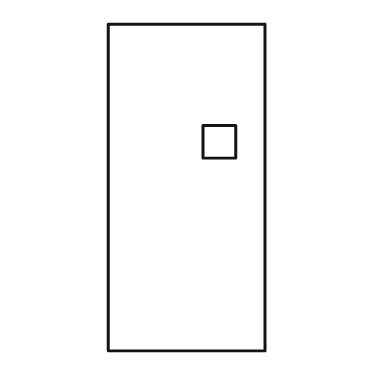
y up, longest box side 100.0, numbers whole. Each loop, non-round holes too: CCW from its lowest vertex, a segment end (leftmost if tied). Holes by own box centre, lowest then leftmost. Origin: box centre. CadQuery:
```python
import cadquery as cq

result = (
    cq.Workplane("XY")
    .moveTo(-24.0, -50.0)
    .lineTo(24.0, -50.0)
    .lineTo(24.0, 50.0)
    .lineTo(-24.0, 50.0)
    .close()
    .moveTo(5.0, 9.0)
    .lineTo(15.0, 9.0)
    .lineTo(15.0, 19.0)
    .lineTo(5.0, 19.0)
    .close()
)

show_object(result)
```